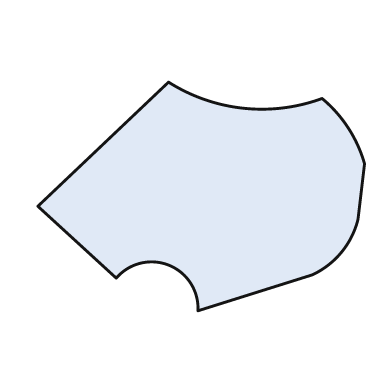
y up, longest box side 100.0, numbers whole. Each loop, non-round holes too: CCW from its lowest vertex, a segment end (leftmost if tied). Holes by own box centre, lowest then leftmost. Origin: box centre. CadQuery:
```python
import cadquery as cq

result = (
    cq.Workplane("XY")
    .moveTo(-1.0, -35.0)
    .lineTo(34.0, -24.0)
    .threePointArc((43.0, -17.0), (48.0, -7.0))
    .lineTo(50.0, 10.0)
    .threePointArc((45.0, 21.0), (37.0, 30.0))
    .threePointArc((13.0, 27.0), (-10.0, 35.0))
    .lineTo(-50.0, -3.0)
    .lineTo(-26.0, -25.0)
    .threePointArc((-10.0, -21.0), (-1.0, -35.0))
    .close()
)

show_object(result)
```